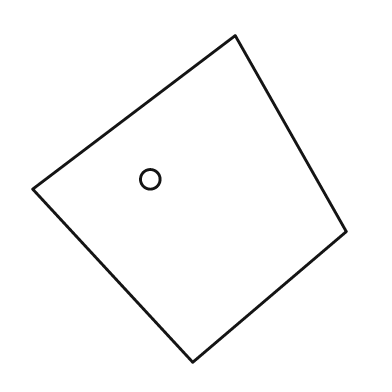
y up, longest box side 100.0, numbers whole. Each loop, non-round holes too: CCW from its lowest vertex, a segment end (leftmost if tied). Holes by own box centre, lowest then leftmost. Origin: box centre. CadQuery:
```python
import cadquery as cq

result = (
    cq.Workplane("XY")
    .moveTo(1.0, -50.0)
    .lineTo(48.0, -10.0)
    .lineTo(14.0, 50.0)
    .lineTo(-48.0, 3.0)
    .close()
    .moveTo(-12.0, 6.0)
    .circle(3.0)
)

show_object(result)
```